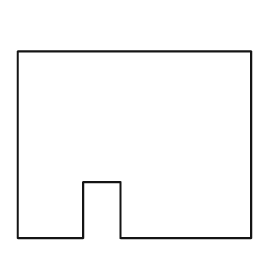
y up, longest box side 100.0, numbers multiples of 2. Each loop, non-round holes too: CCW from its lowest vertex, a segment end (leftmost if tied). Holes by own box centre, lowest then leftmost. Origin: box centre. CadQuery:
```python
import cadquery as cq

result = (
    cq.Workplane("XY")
    .moveTo(-50.0, -40.0)
    .lineTo(-22.0, -40.0)
    .lineTo(-22.0, -16.0)
    .lineTo(-6.0, -16.0)
    .lineTo(-6.0, -40.0)
    .lineTo(50.0, -40.0)
    .lineTo(50.0, 40.0)
    .lineTo(-50.0, 40.0)
    .close()
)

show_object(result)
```